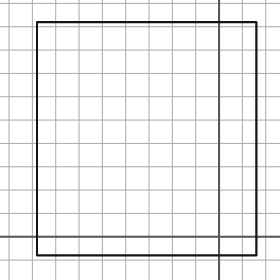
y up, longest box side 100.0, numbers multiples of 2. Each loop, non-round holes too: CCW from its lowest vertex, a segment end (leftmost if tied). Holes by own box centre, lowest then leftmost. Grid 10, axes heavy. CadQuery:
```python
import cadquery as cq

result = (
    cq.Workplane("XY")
    .moveTo(-78.0, -8.0)
    .lineTo(16.0, -8.0)
    .lineTo(16.0, 92.0)
    .lineTo(-78.0, 92.0)
    .close()
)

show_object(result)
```